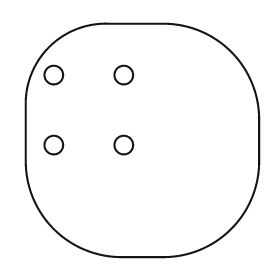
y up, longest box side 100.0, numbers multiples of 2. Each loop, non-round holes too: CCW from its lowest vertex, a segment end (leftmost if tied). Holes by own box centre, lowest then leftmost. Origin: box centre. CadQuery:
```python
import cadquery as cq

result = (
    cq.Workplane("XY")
    .moveTo(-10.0, -50.0)
    .lineTo(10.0, -50.0)
    .threePointArc((38.0, -38.0), (50.0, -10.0))
    .lineTo(50.0, 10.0)
    .threePointArc((38.0, 38.0), (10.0, 50.0))
    .lineTo(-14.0, 50.0)
    .threePointArc((-40.0, 40.0), (-50.0, 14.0))
    .lineTo(-50.0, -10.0)
    .threePointArc((-38.0, -38.0), (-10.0, -50.0))
    .close()
    .moveTo(-38.0, -2.0)
    .circle(4.0)
    .moveTo(-8.0, -2.0)
    .circle(4.0)
    .moveTo(-38.0, 28.0)
    .circle(4.0)
    .moveTo(-8.0, 28.0)
    .circle(4.0)
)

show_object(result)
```